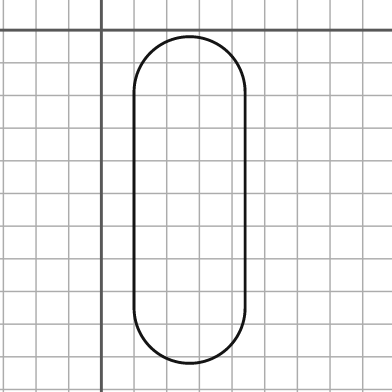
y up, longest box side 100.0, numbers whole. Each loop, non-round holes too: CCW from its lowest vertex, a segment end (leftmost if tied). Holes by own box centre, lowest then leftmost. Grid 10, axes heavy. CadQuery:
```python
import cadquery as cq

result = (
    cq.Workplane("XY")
    .moveTo(10.0, -85.0)
    .threePointArc((27.0, -102.0), (44.0, -85.0))
    .lineTo(44.0, -19.0)
    .threePointArc((27.0, -2.0), (10.0, -19.0))
    .close()
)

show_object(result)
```